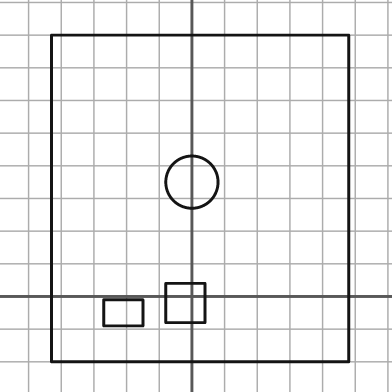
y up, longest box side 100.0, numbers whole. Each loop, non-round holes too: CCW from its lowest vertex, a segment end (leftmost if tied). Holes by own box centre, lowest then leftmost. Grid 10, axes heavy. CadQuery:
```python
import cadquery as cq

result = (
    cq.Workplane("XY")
    .moveTo(-43.0, -20.0)
    .lineTo(48.0, -20.0)
    .lineTo(48.0, 80.0)
    .lineTo(-43.0, 80.0)
    .close()
    .moveTo(-27.0, -9.0)
    .lineTo(-15.0, -9.0)
    .lineTo(-15.0, -1.0)
    .lineTo(-27.0, -1.0)
    .close()
    .moveTo(-8.0, -8.0)
    .lineTo(4.0, -8.0)
    .lineTo(4.0, 4.0)
    .lineTo(-8.0, 4.0)
    .close()
    .moveTo(0.0, 35.0)
    .circle(8.0)
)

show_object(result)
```